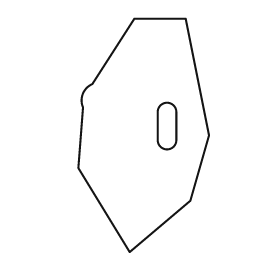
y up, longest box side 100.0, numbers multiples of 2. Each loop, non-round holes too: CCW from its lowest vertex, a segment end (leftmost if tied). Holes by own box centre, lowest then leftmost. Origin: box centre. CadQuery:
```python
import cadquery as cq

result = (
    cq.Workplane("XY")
    .moveTo(-6.0, -50.0)
    .lineTo(20.0, -28.0)
    .lineTo(28.0, 0.0)
    .lineTo(18.0, 50.0)
    .lineTo(-4.0, 50.0)
    .lineTo(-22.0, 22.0)
    .threePointArc((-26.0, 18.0), (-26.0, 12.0))
    .lineTo(-28.0, -14.0)
    .close()
    .moveTo(6.0, -2.0)
    .threePointArc((10.0, -6.0), (14.0, -2.0))
    .lineTo(14.0, 10.0)
    .threePointArc((10.0, 14.0), (6.0, 10.0))
    .close()
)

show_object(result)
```